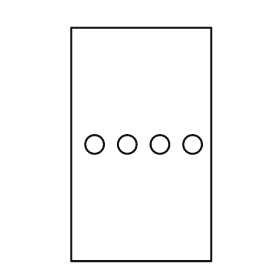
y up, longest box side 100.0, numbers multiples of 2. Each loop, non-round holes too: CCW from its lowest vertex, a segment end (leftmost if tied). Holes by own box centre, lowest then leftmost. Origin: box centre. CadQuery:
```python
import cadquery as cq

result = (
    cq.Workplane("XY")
    .moveTo(-30.0, -50.0)
    .lineTo(30.0, -50.0)
    .lineTo(30.0, 50.0)
    .lineTo(-30.0, 50.0)
    .close()
    .moveTo(-20.0, 0.0)
    .circle(4.0)
    .moveTo(-6.0, 0.0)
    .circle(4.0)
    .moveTo(8.0, 0.0)
    .circle(4.0)
    .moveTo(22.0, 0.0)
    .circle(4.0)
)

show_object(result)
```